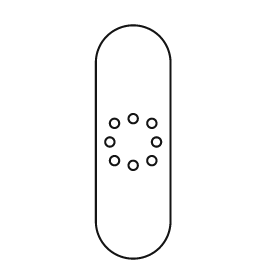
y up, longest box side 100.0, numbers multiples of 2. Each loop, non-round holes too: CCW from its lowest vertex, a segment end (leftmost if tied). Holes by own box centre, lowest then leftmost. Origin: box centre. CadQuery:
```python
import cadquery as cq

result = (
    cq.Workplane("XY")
    .moveTo(-16.0, -34.0)
    .threePointArc((0.0, -50.0), (16.0, -34.0))
    .lineTo(16.0, 34.0)
    .threePointArc((0.0, 50.0), (-16.0, 34.0))
    .close()
    .moveTo(0.0, -10.0)
    .circle(2.0)
    .moveTo(-8.0, -8.0)
    .circle(2.0)
    .moveTo(8.0, -8.0)
    .circle(2.0)
    .moveTo(-10.0, 0.0)
    .circle(2.0)
    .moveTo(10.0, 0.0)
    .circle(2.0)
    .moveTo(-8.0, 8.0)
    .circle(2.0)
    .moveTo(8.0, 8.0)
    .circle(2.0)
    .moveTo(0.0, 10.0)
    .circle(2.0)
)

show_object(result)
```